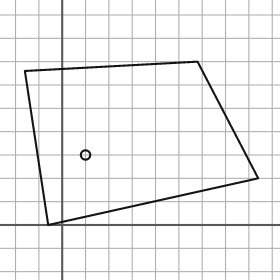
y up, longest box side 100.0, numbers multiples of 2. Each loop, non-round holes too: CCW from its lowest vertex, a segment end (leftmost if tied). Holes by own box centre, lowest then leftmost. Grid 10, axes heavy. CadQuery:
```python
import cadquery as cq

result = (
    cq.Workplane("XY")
    .moveTo(-6.0, 0.0)
    .lineTo(84.0, 20.0)
    .lineTo(58.0, 70.0)
    .lineTo(-16.0, 66.0)
    .close()
    .moveTo(10.0, 30.0)
    .circle(2.0)
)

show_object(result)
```